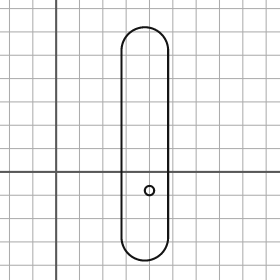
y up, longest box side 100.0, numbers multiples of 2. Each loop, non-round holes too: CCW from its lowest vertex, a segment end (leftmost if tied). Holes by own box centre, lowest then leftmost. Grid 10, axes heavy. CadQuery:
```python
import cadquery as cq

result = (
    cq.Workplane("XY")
    .moveTo(28.0, -28.0)
    .threePointArc((38.0, -38.0), (48.0, -28.0))
    .lineTo(48.0, 52.0)
    .threePointArc((38.0, 62.0), (28.0, 52.0))
    .close()
    .moveTo(40.0, -8.0)
    .circle(2.0)
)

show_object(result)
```